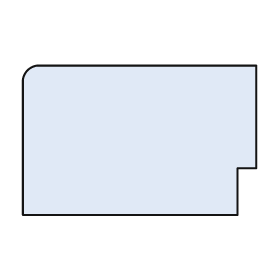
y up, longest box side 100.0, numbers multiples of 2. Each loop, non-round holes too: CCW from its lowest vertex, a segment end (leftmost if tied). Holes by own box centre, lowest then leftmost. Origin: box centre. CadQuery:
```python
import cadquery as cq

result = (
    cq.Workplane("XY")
    .moveTo(-50.0, -32.0)
    .lineTo(42.0, -32.0)
    .lineTo(42.0, -12.0)
    .lineTo(50.0, -12.0)
    .lineTo(50.0, 32.0)
    .lineTo(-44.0, 32.0)
    .threePointArc((-48.0, 30.0), (-50.0, 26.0))
    .close()
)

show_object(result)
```